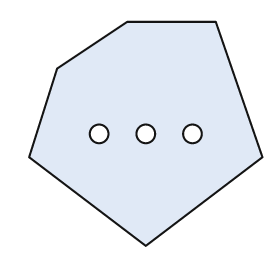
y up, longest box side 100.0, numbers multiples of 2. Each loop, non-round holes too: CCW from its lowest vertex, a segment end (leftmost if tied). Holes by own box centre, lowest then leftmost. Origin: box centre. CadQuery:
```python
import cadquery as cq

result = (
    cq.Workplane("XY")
    .moveTo(0.0, -48.0)
    .lineTo(50.0, -10.0)
    .lineTo(30.0, 48.0)
    .lineTo(-8.0, 48.0)
    .lineTo(-38.0, 28.0)
    .lineTo(-50.0, -10.0)
    .close()
    .moveTo(-20.0, 0.0)
    .circle(4.0)
    .moveTo(0.0, 0.0)
    .circle(4.0)
    .moveTo(20.0, 0.0)
    .circle(4.0)
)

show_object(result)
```